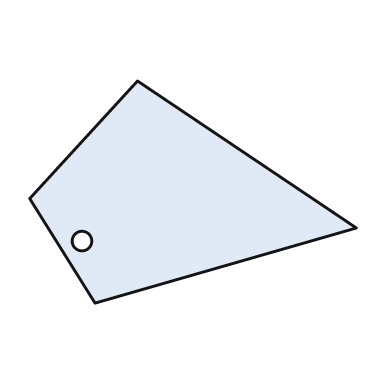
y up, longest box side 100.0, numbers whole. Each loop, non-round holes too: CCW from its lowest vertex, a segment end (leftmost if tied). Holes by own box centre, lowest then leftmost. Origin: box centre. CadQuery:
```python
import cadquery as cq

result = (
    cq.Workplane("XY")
    .moveTo(-30.0, -34.0)
    .lineTo(50.0, -11.0)
    .lineTo(-17.0, 34.0)
    .lineTo(-50.0, -2.0)
    .close()
    .moveTo(-34.0, -15.0)
    .circle(3.0)
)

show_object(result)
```